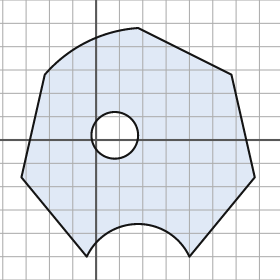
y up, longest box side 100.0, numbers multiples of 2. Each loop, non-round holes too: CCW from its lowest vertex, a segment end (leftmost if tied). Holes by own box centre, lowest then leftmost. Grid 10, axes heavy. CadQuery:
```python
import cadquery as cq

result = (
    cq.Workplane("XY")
    .moveTo(-4.0, -50.0)
    .threePointArc((18.0, -36.0), (40.0, -50.0))
    .lineTo(68.0, -16.0)
    .lineTo(58.0, 28.0)
    .lineTo(18.0, 48.0)
    .threePointArc((-4.0, 42.0), (-22.0, 28.0))
    .lineTo(-32.0, -16.0)
    .close()
    .moveTo(8.0, 2.0)
    .circle(10.0)
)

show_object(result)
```